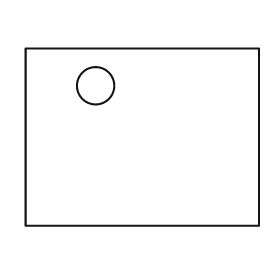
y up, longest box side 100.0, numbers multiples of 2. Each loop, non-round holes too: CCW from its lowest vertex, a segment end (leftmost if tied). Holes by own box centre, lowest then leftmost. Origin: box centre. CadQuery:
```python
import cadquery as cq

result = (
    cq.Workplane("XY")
    .moveTo(-50.0, -38.0)
    .lineTo(50.0, -38.0)
    .lineTo(50.0, 38.0)
    .lineTo(-50.0, 38.0)
    .close()
    .moveTo(-20.0, 22.0)
    .circle(8.0)
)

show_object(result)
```